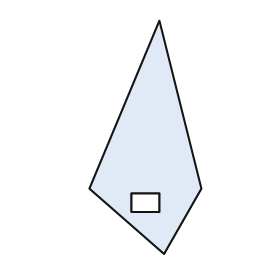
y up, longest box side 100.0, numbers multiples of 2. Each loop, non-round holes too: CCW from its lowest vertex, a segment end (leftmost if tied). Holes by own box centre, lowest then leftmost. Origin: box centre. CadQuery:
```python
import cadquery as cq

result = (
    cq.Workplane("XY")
    .moveTo(8.0, -50.0)
    .lineTo(24.0, -22.0)
    .lineTo(6.0, 50.0)
    .lineTo(-24.0, -22.0)
    .close()
    .moveTo(-6.0, -32.0)
    .lineTo(6.0, -32.0)
    .lineTo(6.0, -24.0)
    .lineTo(-6.0, -24.0)
    .close()
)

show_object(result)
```